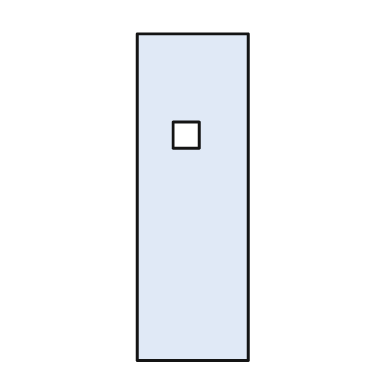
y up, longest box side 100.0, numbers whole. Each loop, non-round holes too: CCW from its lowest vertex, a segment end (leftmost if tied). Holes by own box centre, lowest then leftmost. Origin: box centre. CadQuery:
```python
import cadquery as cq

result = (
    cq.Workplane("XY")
    .moveTo(-17.0, -50.0)
    .lineTo(17.0, -50.0)
    .lineTo(17.0, 50.0)
    .lineTo(-17.0, 50.0)
    .close()
    .moveTo(-6.0, 15.0)
    .lineTo(2.0, 15.0)
    .lineTo(2.0, 23.0)
    .lineTo(-6.0, 23.0)
    .close()
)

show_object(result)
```